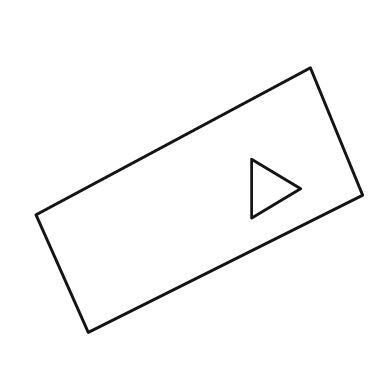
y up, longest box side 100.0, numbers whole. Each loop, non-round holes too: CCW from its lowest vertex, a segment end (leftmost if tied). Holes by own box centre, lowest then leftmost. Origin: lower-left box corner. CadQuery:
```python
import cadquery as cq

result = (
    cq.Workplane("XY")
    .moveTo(16.0, 0.0)
    .lineTo(100.0, 42.0)
    .lineTo(84.0, 81.0)
    .lineTo(0.0, 36.0)
    .close()
    .moveTo(66.0, 35.0)
    .lineTo(81.0, 44.0)
    .lineTo(66.0, 53.0)
    .close()
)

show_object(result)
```